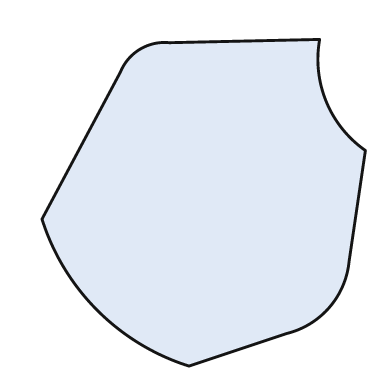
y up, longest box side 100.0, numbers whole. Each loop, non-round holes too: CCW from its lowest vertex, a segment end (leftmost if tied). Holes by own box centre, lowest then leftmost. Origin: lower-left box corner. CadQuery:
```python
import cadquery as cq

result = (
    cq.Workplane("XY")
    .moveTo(45.0, 0.0)
    .lineTo(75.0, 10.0)
    .threePointArc((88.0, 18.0), (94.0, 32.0))
    .lineTo(99.0, 66.0)
    .threePointArc((87.0, 81.0), (85.0, 100.0))
    .lineTo(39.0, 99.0)
    .threePointArc((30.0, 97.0), (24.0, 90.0))
    .lineTo(0.0, 45.0)
    .threePointArc((17.0, 17.0), (45.0, 0.0))
    .close()
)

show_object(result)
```